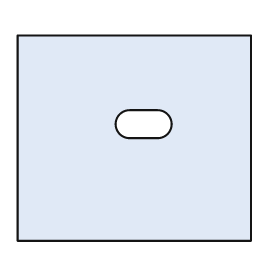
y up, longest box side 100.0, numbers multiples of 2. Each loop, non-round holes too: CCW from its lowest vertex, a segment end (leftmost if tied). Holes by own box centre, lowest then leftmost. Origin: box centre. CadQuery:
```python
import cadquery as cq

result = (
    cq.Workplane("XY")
    .moveTo(-50.0, -44.0)
    .lineTo(50.0, -44.0)
    .lineTo(50.0, 44.0)
    .lineTo(-50.0, 44.0)
    .close()
    .moveTo(-2.0, 0.0)
    .lineTo(10.0, 0.0)
    .threePointArc((16.0, 6.0), (10.0, 12.0))
    .lineTo(-2.0, 12.0)
    .threePointArc((-8.0, 6.0), (-2.0, 0.0))
    .close()
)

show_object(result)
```